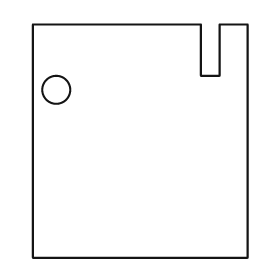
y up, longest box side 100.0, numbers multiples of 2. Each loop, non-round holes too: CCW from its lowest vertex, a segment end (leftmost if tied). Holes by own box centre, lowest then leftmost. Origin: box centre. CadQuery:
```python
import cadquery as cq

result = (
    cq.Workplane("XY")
    .moveTo(-46.0, -50.0)
    .lineTo(46.0, -50.0)
    .lineTo(46.0, 50.0)
    .lineTo(34.0, 50.0)
    .lineTo(34.0, 28.0)
    .lineTo(26.0, 28.0)
    .lineTo(26.0, 50.0)
    .lineTo(-46.0, 50.0)
    .close()
    .moveTo(-36.0, 22.0)
    .circle(6.0)
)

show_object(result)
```